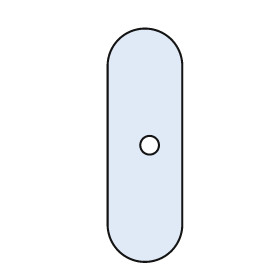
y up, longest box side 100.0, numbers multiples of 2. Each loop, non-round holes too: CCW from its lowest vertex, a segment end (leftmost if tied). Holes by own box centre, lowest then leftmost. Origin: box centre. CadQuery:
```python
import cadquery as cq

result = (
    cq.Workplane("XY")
    .moveTo(-16.0, -34.0)
    .threePointArc((0.0, -50.0), (16.0, -34.0))
    .lineTo(16.0, 34.0)
    .threePointArc((0.0, 50.0), (-16.0, 34.0))
    .close()
    .moveTo(2.0, 0.0)
    .circle(4.0)
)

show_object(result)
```